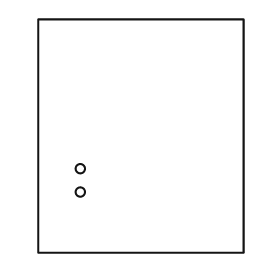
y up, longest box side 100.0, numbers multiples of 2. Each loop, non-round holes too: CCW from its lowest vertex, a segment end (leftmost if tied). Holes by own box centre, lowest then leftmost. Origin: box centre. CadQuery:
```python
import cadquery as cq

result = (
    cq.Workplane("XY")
    .moveTo(-44.0, -50.0)
    .lineTo(44.0, -50.0)
    .lineTo(44.0, 50.0)
    .lineTo(-44.0, 50.0)
    .close()
    .moveTo(-26.0, -24.0)
    .circle(2.0)
    .moveTo(-26.0, -14.0)
    .circle(2.0)
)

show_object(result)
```